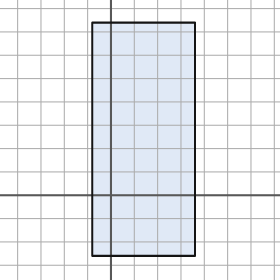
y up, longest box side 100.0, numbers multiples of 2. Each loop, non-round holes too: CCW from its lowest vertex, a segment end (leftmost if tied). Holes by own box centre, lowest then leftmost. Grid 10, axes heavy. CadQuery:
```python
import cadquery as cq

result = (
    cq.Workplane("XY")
    .moveTo(-8.0, -26.0)
    .lineTo(36.0, -26.0)
    .lineTo(36.0, 74.0)
    .lineTo(-8.0, 74.0)
    .close()
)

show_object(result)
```